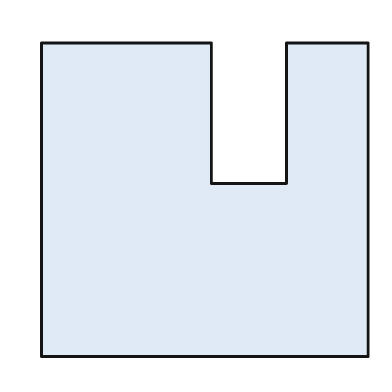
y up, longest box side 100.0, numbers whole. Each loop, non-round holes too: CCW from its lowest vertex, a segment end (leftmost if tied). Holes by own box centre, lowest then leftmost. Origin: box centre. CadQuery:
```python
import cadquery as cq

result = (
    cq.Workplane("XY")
    .moveTo(-50.0, -48.0)
    .lineTo(50.0, -48.0)
    .lineTo(50.0, 48.0)
    .lineTo(25.0, 48.0)
    .lineTo(25.0, 5.0)
    .lineTo(2.0, 5.0)
    .lineTo(2.0, 48.0)
    .lineTo(-50.0, 48.0)
    .close()
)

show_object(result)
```